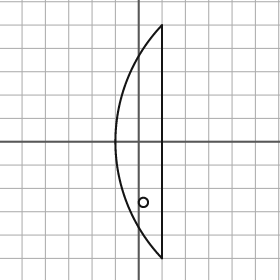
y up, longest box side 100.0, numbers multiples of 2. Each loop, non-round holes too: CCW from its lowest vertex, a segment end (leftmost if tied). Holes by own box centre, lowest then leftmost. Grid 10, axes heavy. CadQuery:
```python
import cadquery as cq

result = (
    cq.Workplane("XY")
    .moveTo(10.0, -50.0)
    .lineTo(10.0, 50.0)
    .threePointArc((-10.0, 0.0), (10.0, -50.0))
    .close()
    .moveTo(2.0, -26.0)
    .circle(2.0)
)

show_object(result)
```